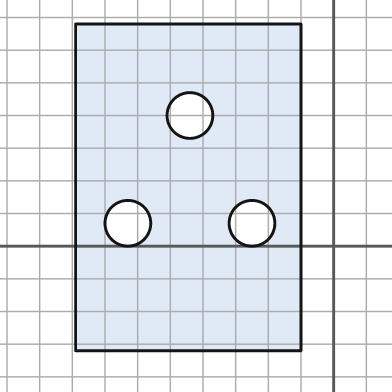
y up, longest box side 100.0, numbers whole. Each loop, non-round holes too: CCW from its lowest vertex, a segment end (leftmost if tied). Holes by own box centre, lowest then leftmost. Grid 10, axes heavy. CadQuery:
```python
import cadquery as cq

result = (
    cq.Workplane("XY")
    .moveTo(-79.0, -32.0)
    .lineTo(-10.0, -32.0)
    .lineTo(-10.0, 68.0)
    .lineTo(-79.0, 68.0)
    .close()
    .moveTo(-63.0, 7.0)
    .circle(7.0)
    .moveTo(-25.0, 7.0)
    .circle(7.0)
    .moveTo(-44.0, 40.0)
    .circle(7.0)
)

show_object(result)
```